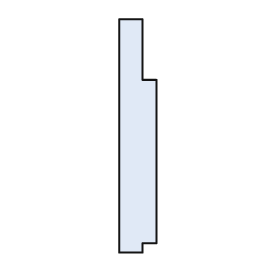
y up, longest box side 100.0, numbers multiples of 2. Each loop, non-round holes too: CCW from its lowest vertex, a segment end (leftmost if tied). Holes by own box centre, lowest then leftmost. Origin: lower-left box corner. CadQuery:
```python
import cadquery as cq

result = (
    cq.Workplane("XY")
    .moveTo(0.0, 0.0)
    .lineTo(10.0, 0.0)
    .lineTo(10.0, 4.0)
    .lineTo(16.0, 4.0)
    .lineTo(16.0, 74.0)
    .lineTo(10.0, 74.0)
    .lineTo(10.0, 100.0)
    .lineTo(0.0, 100.0)
    .close()
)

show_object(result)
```